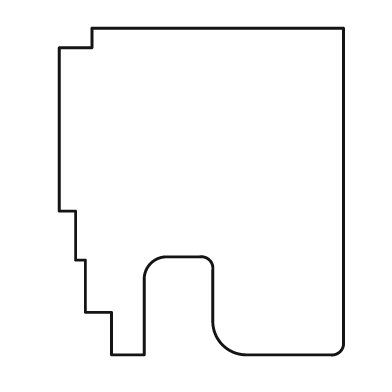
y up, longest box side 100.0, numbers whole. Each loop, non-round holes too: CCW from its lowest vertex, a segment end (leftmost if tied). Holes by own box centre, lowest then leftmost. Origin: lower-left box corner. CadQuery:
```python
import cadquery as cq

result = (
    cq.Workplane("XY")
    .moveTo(16.0, 0.0)
    .lineTo(26.0, 0.0)
    .lineTo(26.0, 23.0)
    .threePointArc((28.0, 28.0), (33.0, 30.0))
    .lineTo(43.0, 30.0)
    .threePointArc((46.0, 29.0), (47.0, 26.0))
    .lineTo(47.0, 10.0)
    .threePointArc((50.0, 3.0), (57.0, 0.0))
    .lineTo(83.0, 0.0)
    .threePointArc((86.0, 1.0), (87.0, 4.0))
    .lineTo(87.0, 100.0)
    .lineTo(10.0, 100.0)
    .lineTo(10.0, 94.0)
    .lineTo(0.0, 94.0)
    .lineTo(0.0, 44.0)
    .lineTo(5.0, 44.0)
    .lineTo(5.0, 29.0)
    .lineTo(8.0, 29.0)
    .lineTo(8.0, 13.0)
    .lineTo(16.0, 13.0)
    .close()
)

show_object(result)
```